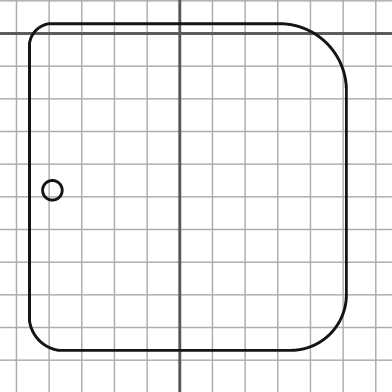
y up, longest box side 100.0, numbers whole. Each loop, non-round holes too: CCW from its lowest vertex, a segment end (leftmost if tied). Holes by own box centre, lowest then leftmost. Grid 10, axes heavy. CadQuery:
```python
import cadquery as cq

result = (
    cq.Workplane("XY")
    .moveTo(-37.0, -97.0)
    .lineTo(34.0, -97.0)
    .threePointArc((46.0, -92.0), (51.0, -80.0))
    .lineTo(51.0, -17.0)
    .threePointArc((45.0, -3.0), (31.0, 3.0))
    .lineTo(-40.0, 3.0)
    .threePointArc((-44.0, 1.0), (-46.0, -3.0))
    .lineTo(-46.0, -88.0)
    .threePointArc((-43.0, -94.0), (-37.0, -97.0))
    .close()
    .moveTo(-39.0, -48.0)
    .circle(3.0)
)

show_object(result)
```